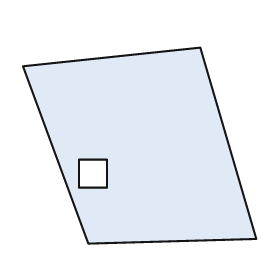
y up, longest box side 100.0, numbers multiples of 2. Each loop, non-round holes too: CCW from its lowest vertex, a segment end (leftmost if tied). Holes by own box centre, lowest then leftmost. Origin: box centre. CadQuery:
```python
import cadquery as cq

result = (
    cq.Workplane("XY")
    .moveTo(-22.0, -42.0)
    .lineTo(50.0, -40.0)
    .lineTo(26.0, 42.0)
    .lineTo(-50.0, 34.0)
    .close()
    .moveTo(-26.0, -18.0)
    .lineTo(-14.0, -18.0)
    .lineTo(-14.0, -6.0)
    .lineTo(-26.0, -6.0)
    .close()
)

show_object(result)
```